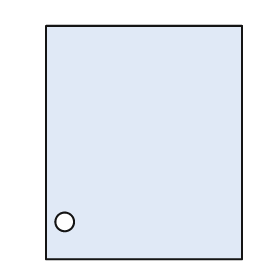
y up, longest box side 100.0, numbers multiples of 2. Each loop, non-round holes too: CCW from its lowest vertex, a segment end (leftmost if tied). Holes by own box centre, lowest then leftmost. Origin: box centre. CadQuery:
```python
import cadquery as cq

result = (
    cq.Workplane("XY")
    .moveTo(-42.0, -50.0)
    .lineTo(42.0, -50.0)
    .lineTo(42.0, 50.0)
    .lineTo(-42.0, 50.0)
    .close()
    .moveTo(-34.0, -34.0)
    .circle(4.0)
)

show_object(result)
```